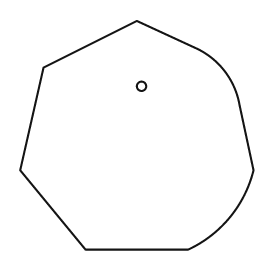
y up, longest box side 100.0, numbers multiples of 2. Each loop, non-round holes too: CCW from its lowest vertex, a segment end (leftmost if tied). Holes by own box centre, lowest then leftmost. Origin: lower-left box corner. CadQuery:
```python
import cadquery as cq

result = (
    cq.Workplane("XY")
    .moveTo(28.0, 0.0)
    .lineTo(72.0, 0.0)
    .threePointArc((90.0, 14.0), (100.0, 34.0))
    .lineTo(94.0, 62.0)
    .threePointArc((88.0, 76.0), (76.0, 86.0))
    .lineTo(50.0, 98.0)
    .lineTo(10.0, 78.0)
    .lineTo(0.0, 34.0)
    .close()
    .moveTo(52.0, 70.0)
    .circle(2.0)
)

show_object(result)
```